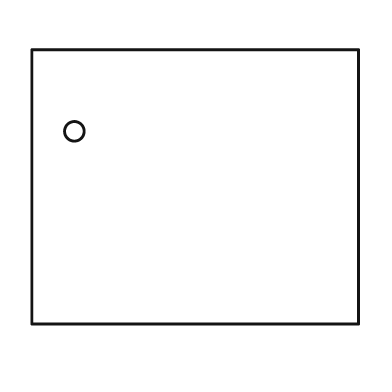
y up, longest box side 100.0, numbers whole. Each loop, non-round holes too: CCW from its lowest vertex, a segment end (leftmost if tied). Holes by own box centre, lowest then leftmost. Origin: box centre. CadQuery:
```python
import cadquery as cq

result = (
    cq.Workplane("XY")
    .moveTo(-50.0, -42.0)
    .lineTo(50.0, -42.0)
    .lineTo(50.0, 42.0)
    .lineTo(-50.0, 42.0)
    .close()
    .moveTo(-37.0, 17.0)
    .circle(3.0)
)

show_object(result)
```